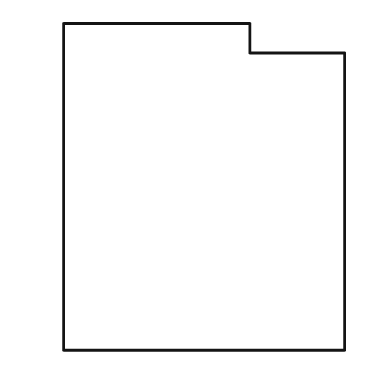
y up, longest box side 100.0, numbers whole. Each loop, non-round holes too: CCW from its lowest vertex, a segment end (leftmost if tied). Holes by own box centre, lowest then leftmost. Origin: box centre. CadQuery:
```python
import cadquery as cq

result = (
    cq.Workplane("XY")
    .moveTo(-43.0, -50.0)
    .lineTo(43.0, -50.0)
    .lineTo(43.0, 41.0)
    .lineTo(14.0, 41.0)
    .lineTo(14.0, 50.0)
    .lineTo(-43.0, 50.0)
    .close()
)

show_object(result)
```